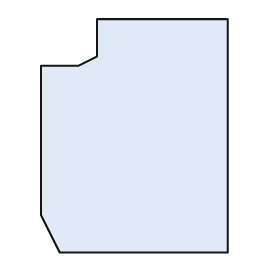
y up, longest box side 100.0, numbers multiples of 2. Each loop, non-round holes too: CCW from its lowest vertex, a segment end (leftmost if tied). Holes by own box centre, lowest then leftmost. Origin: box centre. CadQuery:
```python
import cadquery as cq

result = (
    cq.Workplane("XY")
    .moveTo(-32.0, -50.0)
    .lineTo(40.0, -50.0)
    .lineTo(40.0, 50.0)
    .lineTo(-16.0, 50.0)
    .lineTo(-16.0, 34.0)
    .lineTo(-24.0, 30.0)
    .lineTo(-40.0, 30.0)
    .lineTo(-40.0, -34.0)
    .close()
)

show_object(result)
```